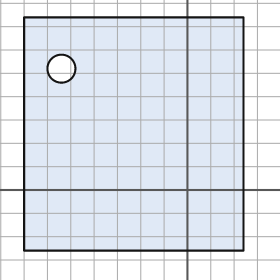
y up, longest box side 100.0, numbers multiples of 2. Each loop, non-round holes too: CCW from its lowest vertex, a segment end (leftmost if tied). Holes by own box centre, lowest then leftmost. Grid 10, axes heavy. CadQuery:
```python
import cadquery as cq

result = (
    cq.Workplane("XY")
    .moveTo(-70.0, -26.0)
    .lineTo(24.0, -26.0)
    .lineTo(24.0, 74.0)
    .lineTo(-70.0, 74.0)
    .close()
    .moveTo(-54.0, 52.0)
    .circle(6.0)
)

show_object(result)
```